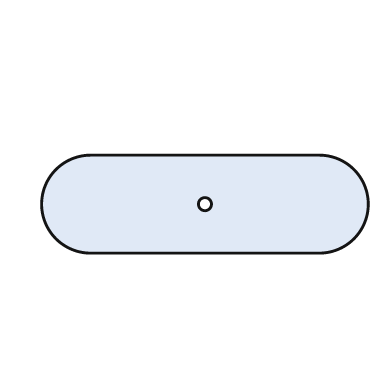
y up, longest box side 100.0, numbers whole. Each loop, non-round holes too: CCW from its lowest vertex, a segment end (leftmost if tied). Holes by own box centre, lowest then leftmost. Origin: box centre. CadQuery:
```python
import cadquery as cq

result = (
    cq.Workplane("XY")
    .moveTo(-35.0, -15.0)
    .lineTo(35.0, -15.0)
    .threePointArc((50.0, 0.0), (35.0, 15.0))
    .lineTo(-35.0, 15.0)
    .threePointArc((-50.0, 0.0), (-35.0, -15.0))
    .close()
    .moveTo(0.0, 0.0)
    .circle(2.0)
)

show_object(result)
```